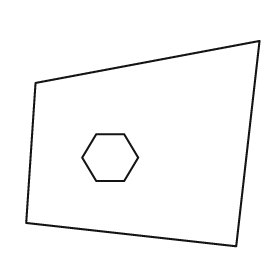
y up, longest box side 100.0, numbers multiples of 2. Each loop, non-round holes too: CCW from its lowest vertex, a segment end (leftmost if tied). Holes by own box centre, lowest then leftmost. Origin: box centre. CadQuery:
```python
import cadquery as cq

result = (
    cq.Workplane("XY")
    .moveTo(40.0, -44.0)
    .lineTo(50.0, 44.0)
    .lineTo(-46.0, 26.0)
    .lineTo(-50.0, -34.0)
    .close()
    .moveTo(-20.0, -16.0)
    .lineTo(-8.0, -16.0)
    .lineTo(-2.0, -6.0)
    .lineTo(-8.0, 4.0)
    .lineTo(-20.0, 4.0)
    .lineTo(-26.0, -6.0)
    .close()
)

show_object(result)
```